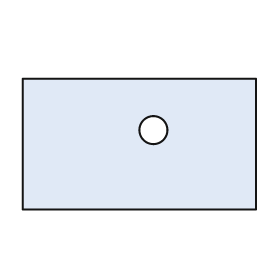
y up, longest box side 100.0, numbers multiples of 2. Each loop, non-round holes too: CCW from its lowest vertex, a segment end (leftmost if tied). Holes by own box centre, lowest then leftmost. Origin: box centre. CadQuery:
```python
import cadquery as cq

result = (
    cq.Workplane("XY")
    .moveTo(-50.0, -28.0)
    .lineTo(50.0, -28.0)
    .lineTo(50.0, 28.0)
    .lineTo(-50.0, 28.0)
    .close()
    .moveTo(6.0, 6.0)
    .circle(6.0)
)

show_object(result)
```